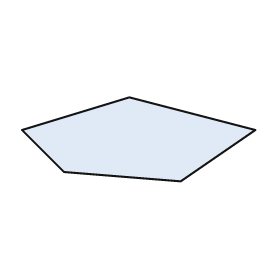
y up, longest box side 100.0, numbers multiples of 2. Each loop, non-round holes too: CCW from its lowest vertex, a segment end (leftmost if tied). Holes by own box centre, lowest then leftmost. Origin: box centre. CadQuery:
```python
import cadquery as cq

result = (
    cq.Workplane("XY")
    .moveTo(18.0, -18.0)
    .lineTo(50.0, 4.0)
    .lineTo(-4.0, 18.0)
    .lineTo(-50.0, 4.0)
    .lineTo(-32.0, -14.0)
    .close()
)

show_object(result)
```